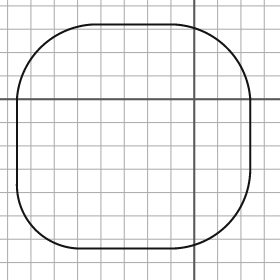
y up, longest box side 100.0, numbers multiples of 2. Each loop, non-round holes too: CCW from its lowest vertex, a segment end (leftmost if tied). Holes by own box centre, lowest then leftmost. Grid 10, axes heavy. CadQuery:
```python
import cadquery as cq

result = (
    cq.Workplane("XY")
    .moveTo(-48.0, -64.0)
    .lineTo(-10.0, -64.0)
    .threePointArc((14.0, -54.0), (24.0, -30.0))
    .lineTo(24.0, 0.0)
    .threePointArc((14.0, 22.0), (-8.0, 32.0))
    .lineTo(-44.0, 32.0)
    .threePointArc((-66.0, 22.0), (-76.0, 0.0))
    .lineTo(-76.0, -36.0)
    .threePointArc((-68.0, -56.0), (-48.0, -64.0))
    .close()
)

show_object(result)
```